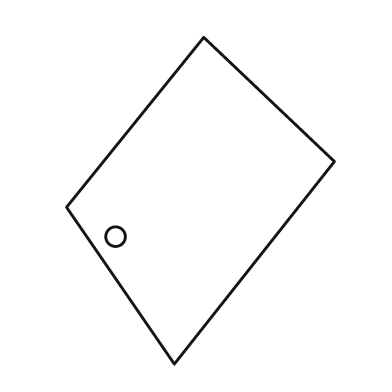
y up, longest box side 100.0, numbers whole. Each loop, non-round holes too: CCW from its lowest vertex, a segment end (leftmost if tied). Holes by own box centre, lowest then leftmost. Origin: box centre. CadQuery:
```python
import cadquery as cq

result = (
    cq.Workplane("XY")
    .moveTo(-8.0, -50.0)
    .lineTo(41.0, 12.0)
    .lineTo(1.0, 50.0)
    .lineTo(-41.0, -2.0)
    .close()
    .moveTo(-26.0, -11.0)
    .circle(3.0)
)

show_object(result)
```